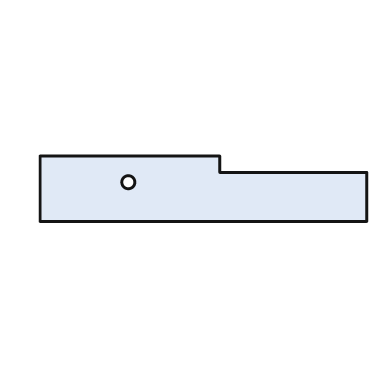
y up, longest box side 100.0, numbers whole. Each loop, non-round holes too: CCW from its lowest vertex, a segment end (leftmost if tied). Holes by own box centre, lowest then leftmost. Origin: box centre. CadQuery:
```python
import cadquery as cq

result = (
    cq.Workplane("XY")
    .moveTo(-50.0, -10.0)
    .lineTo(50.0, -10.0)
    .lineTo(50.0, 5.0)
    .lineTo(5.0, 5.0)
    .lineTo(5.0, 10.0)
    .lineTo(-50.0, 10.0)
    .close()
    .moveTo(-23.0, 2.0)
    .circle(2.0)
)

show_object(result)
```